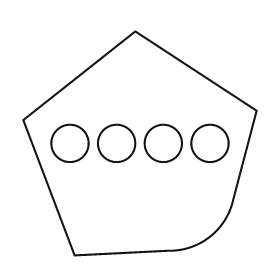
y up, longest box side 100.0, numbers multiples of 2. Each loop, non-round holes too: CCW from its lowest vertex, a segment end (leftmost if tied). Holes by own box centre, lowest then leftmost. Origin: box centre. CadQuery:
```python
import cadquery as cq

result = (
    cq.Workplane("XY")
    .moveTo(-28.0, -48.0)
    .lineTo(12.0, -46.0)
    .threePointArc((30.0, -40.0), (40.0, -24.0))
    .lineTo(50.0, 14.0)
    .lineTo(-2.0, 48.0)
    .lineTo(-50.0, 10.0)
    .close()
    .moveTo(-30.0, 0.0)
    .circle(8.0)
    .moveTo(-10.0, 0.0)
    .circle(8.0)
    .moveTo(10.0, 0.0)
    .circle(8.0)
    .moveTo(30.0, 0.0)
    .circle(8.0)
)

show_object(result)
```